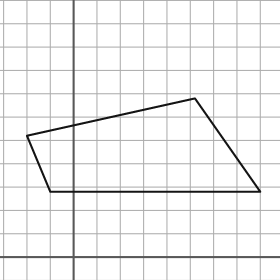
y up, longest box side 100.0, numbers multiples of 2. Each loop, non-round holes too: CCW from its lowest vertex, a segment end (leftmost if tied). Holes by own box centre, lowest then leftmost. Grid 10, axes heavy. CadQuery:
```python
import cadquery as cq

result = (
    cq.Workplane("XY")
    .moveTo(-10.0, 28.0)
    .lineTo(80.0, 28.0)
    .lineTo(52.0, 68.0)
    .lineTo(-20.0, 52.0)
    .close()
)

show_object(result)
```